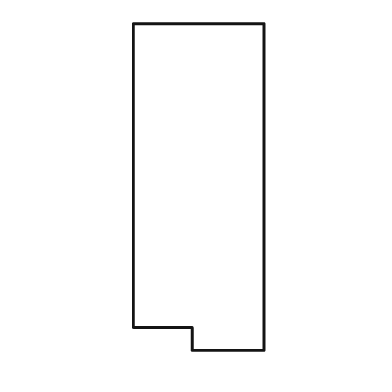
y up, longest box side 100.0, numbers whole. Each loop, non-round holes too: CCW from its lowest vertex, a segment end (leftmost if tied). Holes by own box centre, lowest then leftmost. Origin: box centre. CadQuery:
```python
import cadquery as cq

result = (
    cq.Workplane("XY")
    .moveTo(-2.0, -50.0)
    .lineTo(20.0, -50.0)
    .lineTo(20.0, 50.0)
    .lineTo(-20.0, 50.0)
    .lineTo(-20.0, -43.0)
    .lineTo(-2.0, -43.0)
    .close()
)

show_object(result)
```